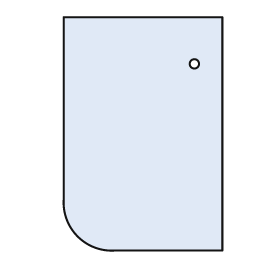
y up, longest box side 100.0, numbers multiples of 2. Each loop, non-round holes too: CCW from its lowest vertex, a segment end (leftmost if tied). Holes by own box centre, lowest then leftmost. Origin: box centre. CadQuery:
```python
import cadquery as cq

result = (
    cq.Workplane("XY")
    .moveTo(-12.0, -50.0)
    .lineTo(34.0, -50.0)
    .lineTo(34.0, 50.0)
    .lineTo(-34.0, 50.0)
    .lineTo(-34.0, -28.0)
    .threePointArc((-28.0, -44.0), (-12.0, -50.0))
    .close()
    .moveTo(22.0, 30.0)
    .circle(2.0)
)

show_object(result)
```